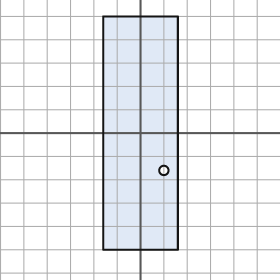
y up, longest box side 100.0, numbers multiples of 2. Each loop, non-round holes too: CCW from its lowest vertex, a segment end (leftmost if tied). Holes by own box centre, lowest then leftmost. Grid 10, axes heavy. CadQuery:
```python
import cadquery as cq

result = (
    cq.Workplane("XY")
    .moveTo(-16.0, -50.0)
    .lineTo(16.0, -50.0)
    .lineTo(16.0, 50.0)
    .lineTo(-16.0, 50.0)
    .close()
    .moveTo(10.0, -16.0)
    .circle(2.0)
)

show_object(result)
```